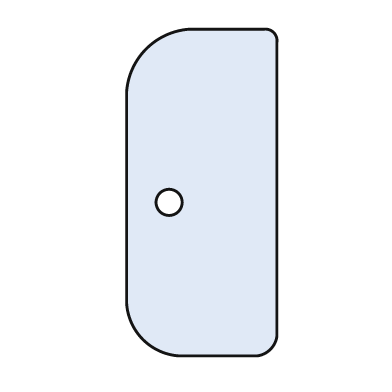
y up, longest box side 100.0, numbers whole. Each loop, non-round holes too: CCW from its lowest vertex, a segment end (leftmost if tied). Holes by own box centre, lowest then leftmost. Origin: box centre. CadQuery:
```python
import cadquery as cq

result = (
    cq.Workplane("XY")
    .moveTo(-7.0, -50.0)
    .lineTo(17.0, -50.0)
    .threePointArc((21.0, -48.0), (23.0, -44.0))
    .lineTo(23.0, 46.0)
    .threePointArc((22.0, 49.0), (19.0, 50.0))
    .lineTo(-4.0, 50.0)
    .threePointArc((-17.0, 44.0), (-23.0, 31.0))
    .lineTo(-23.0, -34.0)
    .threePointArc((-18.0, -45.0), (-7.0, -50.0))
    .close()
    .moveTo(-10.0, -3.0)
    .circle(4.0)
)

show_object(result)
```